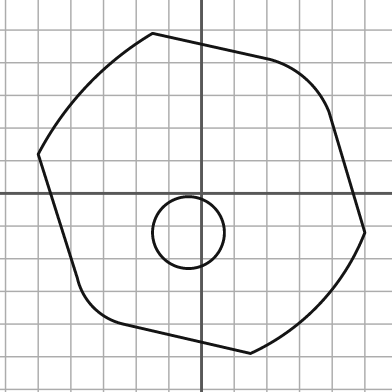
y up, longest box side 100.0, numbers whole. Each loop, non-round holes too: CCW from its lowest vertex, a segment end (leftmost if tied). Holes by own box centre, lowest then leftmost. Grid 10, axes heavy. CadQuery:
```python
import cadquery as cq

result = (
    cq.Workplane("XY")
    .moveTo(15.0, -49.0)
    .threePointArc((36.0, -34.0), (50.0, -12.0))
    .lineTo(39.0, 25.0)
    .threePointArc((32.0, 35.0), (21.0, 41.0))
    .lineTo(-15.0, 49.0)
    .threePointArc((-35.0, 33.0), (-50.0, 12.0))
    .lineTo(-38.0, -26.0)
    .threePointArc((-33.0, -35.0), (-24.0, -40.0))
    .close()
    .moveTo(-4.0, -12.0)
    .circle(11.0)
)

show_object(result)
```